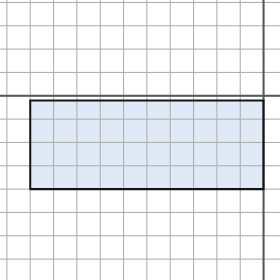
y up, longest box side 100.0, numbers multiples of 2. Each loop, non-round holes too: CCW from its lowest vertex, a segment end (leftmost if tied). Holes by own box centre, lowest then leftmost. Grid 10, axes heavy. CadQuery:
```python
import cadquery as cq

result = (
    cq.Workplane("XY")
    .moveTo(-100.0, -40.0)
    .lineTo(0.0, -40.0)
    .lineTo(0.0, -2.0)
    .lineTo(-100.0, -2.0)
    .close()
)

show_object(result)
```